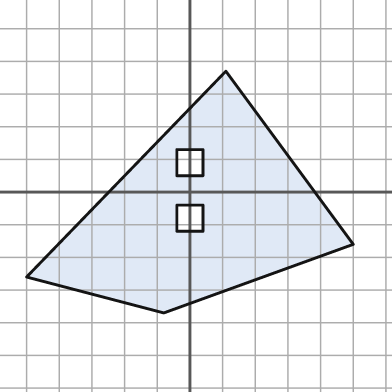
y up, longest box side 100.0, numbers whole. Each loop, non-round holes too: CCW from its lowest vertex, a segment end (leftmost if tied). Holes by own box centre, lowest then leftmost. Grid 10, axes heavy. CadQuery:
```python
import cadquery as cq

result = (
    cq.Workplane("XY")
    .moveTo(-8.0, -37.0)
    .lineTo(50.0, -16.0)
    .lineTo(11.0, 37.0)
    .lineTo(-50.0, -26.0)
    .close()
    .moveTo(-4.0, -12.0)
    .lineTo(4.0, -12.0)
    .lineTo(4.0, -4.0)
    .lineTo(-4.0, -4.0)
    .close()
    .moveTo(-4.0, 5.0)
    .lineTo(4.0, 5.0)
    .lineTo(4.0, 13.0)
    .lineTo(-4.0, 13.0)
    .close()
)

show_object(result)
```